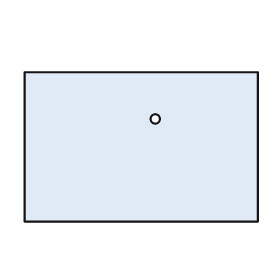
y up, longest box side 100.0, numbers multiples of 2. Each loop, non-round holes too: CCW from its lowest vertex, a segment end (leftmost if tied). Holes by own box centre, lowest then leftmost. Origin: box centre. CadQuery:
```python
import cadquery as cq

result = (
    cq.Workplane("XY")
    .moveTo(-50.0, -32.0)
    .lineTo(50.0, -32.0)
    .lineTo(50.0, 32.0)
    .lineTo(-50.0, 32.0)
    .close()
    .moveTo(6.0, 12.0)
    .circle(2.0)
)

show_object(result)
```